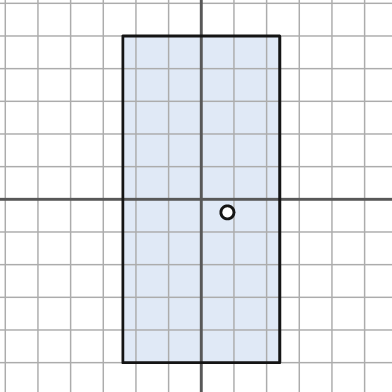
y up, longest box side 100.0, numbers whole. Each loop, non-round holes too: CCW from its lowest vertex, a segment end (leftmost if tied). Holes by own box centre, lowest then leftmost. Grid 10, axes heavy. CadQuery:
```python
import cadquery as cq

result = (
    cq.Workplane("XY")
    .moveTo(-24.0, -50.0)
    .lineTo(24.0, -50.0)
    .lineTo(24.0, 50.0)
    .lineTo(-24.0, 50.0)
    .close()
    .moveTo(8.0, -4.0)
    .circle(2.0)
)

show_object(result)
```